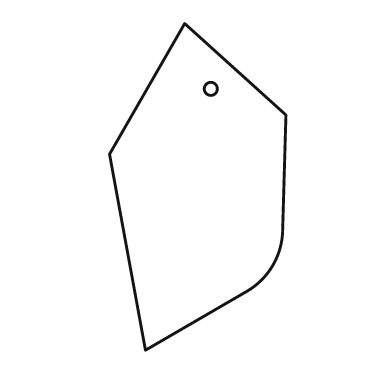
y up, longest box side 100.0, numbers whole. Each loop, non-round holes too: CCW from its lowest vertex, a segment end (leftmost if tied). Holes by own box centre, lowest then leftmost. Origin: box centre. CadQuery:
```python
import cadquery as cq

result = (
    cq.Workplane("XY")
    .moveTo(-16.0, -50.0)
    .lineTo(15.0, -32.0)
    .threePointArc((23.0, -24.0), (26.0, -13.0))
    .lineTo(27.0, 22.0)
    .lineTo(-4.0, 50.0)
    .lineTo(-27.0, 10.0)
    .close()
    .moveTo(4.0, 30.0)
    .circle(2.0)
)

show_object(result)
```